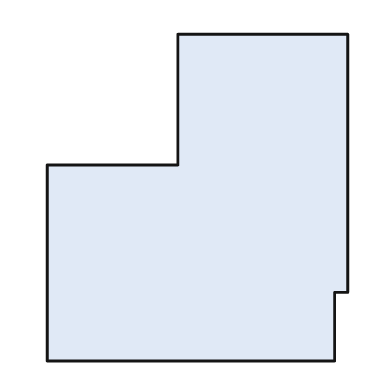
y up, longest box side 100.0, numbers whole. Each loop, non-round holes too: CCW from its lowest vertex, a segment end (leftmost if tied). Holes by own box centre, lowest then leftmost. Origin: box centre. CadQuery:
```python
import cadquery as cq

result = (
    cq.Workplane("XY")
    .moveTo(-46.0, -50.0)
    .lineTo(42.0, -50.0)
    .lineTo(42.0, -29.0)
    .lineTo(46.0, -29.0)
    .lineTo(46.0, 50.0)
    .lineTo(-6.0, 50.0)
    .lineTo(-6.0, 10.0)
    .lineTo(-46.0, 10.0)
    .close()
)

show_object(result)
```